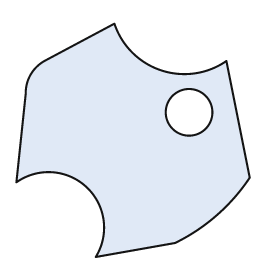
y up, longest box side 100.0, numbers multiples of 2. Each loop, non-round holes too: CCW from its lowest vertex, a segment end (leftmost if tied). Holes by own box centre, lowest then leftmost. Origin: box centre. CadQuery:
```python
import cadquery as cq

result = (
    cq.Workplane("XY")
    .moveTo(-16.0, -50.0)
    .lineTo(18.0, -44.0)
    .threePointArc((36.0, -32.0), (50.0, -16.0))
    .lineTo(40.0, 34.0)
    .threePointArc((12.0, 30.0), (-8.0, 50.0))
    .lineTo(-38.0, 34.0)
    .threePointArc((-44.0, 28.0), (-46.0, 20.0))
    .lineTo(-50.0, -18.0)
    .threePointArc((-20.0, -20.0), (-16.0, -50.0))
    .close()
    .moveTo(24.0, 12.0)
    .circle(10.0)
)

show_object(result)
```